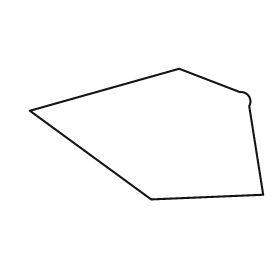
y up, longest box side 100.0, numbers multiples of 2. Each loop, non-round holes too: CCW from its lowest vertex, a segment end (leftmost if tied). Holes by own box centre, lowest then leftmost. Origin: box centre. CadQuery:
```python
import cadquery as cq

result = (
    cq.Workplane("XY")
    .moveTo(2.0, -28.0)
    .lineTo(50.0, -26.0)
    .lineTo(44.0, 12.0)
    .threePointArc((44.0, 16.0), (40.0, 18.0))
    .lineTo(14.0, 28.0)
    .lineTo(-50.0, 10.0)
    .close()
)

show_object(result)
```